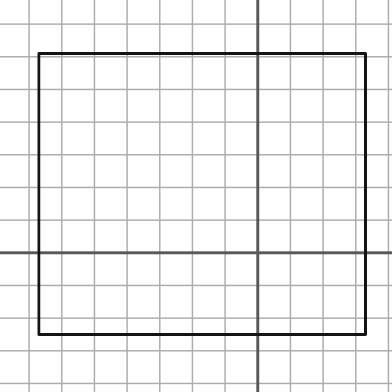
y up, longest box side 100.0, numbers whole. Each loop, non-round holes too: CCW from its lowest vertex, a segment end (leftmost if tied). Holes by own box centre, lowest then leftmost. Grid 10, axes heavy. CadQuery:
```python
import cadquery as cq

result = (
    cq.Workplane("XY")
    .moveTo(-67.0, -25.0)
    .lineTo(33.0, -25.0)
    .lineTo(33.0, 61.0)
    .lineTo(-67.0, 61.0)
    .close()
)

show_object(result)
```